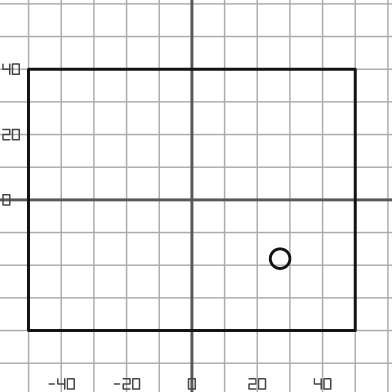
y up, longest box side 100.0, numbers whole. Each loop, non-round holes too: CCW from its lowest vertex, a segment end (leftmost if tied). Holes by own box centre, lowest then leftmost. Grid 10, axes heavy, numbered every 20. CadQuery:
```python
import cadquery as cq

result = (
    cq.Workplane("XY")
    .moveTo(-50.0, -40.0)
    .lineTo(50.0, -40.0)
    .lineTo(50.0, 40.0)
    .lineTo(-50.0, 40.0)
    .close()
    .moveTo(27.0, -18.0)
    .circle(3.0)
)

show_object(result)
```